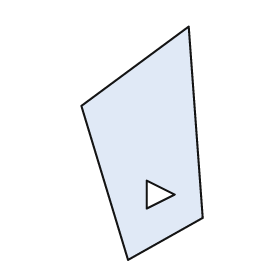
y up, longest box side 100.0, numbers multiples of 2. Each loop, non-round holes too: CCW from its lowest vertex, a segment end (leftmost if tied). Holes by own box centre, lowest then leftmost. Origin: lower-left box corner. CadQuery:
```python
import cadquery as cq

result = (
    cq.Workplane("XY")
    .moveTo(20.0, 0.0)
    .lineTo(52.0, 18.0)
    .lineTo(46.0, 100.0)
    .lineTo(0.0, 66.0)
    .close()
    .moveTo(28.0, 22.0)
    .lineTo(40.0, 28.0)
    .lineTo(28.0, 34.0)
    .close()
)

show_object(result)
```